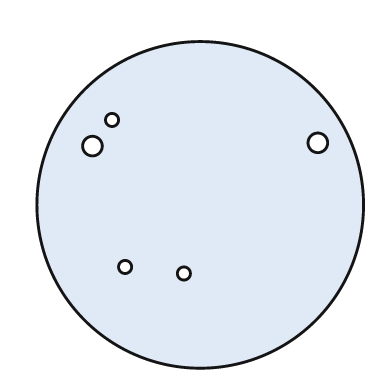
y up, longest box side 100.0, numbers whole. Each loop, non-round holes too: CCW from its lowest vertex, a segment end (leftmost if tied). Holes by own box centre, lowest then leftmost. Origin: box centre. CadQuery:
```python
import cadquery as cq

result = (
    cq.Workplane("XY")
    .moveTo(0.0, 0.0)
    .circle(50.0)
    .moveTo(-5.0, -21.0)
    .circle(2.0)
    .moveTo(-23.0, -19.0)
    .circle(2.0)
    .moveTo(-33.0, 18.0)
    .circle(3.0)
    .moveTo(36.0, 19.0)
    .circle(3.0)
    .moveTo(-27.0, 26.0)
    .circle(2.0)
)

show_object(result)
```